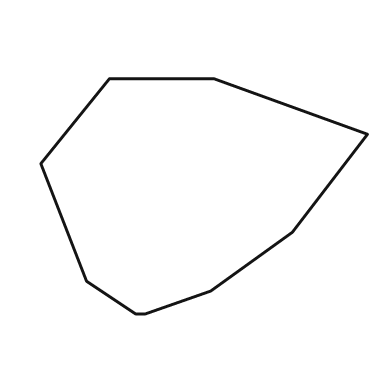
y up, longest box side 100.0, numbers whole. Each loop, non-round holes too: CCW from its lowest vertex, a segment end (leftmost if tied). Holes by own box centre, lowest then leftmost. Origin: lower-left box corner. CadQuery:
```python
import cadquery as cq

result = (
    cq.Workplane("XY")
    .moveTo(29.0, 0.0)
    .lineTo(32.0, 0.0)
    .lineTo(52.0, 7.0)
    .lineTo(77.0, 25.0)
    .lineTo(100.0, 55.0)
    .lineTo(53.0, 72.0)
    .lineTo(21.0, 72.0)
    .lineTo(0.0, 46.0)
    .lineTo(14.0, 10.0)
    .close()
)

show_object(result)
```